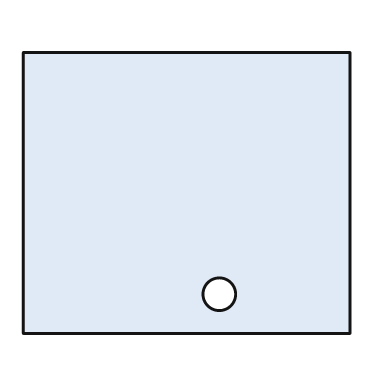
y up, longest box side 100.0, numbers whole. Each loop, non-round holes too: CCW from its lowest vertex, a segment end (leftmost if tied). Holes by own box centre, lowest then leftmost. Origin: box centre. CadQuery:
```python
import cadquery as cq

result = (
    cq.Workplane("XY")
    .moveTo(-50.0, -43.0)
    .lineTo(50.0, -43.0)
    .lineTo(50.0, 43.0)
    .lineTo(-50.0, 43.0)
    .close()
    .moveTo(10.0, -31.0)
    .circle(5.0)
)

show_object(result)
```